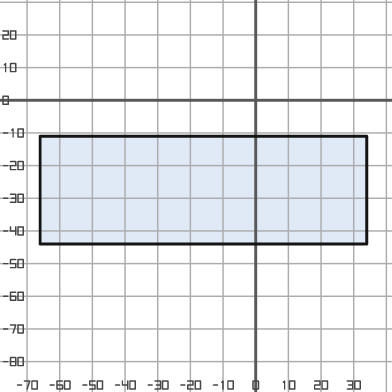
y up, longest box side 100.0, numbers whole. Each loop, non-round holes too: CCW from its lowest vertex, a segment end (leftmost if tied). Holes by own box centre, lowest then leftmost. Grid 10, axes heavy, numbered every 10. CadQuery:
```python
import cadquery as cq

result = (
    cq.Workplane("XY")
    .moveTo(-66.0, -44.0)
    .lineTo(34.0, -44.0)
    .lineTo(34.0, -11.0)
    .lineTo(-66.0, -11.0)
    .close()
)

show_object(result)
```